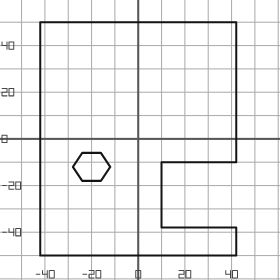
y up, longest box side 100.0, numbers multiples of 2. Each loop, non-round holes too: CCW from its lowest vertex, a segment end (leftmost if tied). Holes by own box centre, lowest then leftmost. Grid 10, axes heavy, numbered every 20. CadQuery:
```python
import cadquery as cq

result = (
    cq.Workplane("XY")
    .moveTo(-42.0, -50.0)
    .lineTo(42.0, -50.0)
    .lineTo(42.0, -38.0)
    .lineTo(10.0, -38.0)
    .lineTo(10.0, -10.0)
    .lineTo(42.0, -10.0)
    .lineTo(42.0, 50.0)
    .lineTo(-42.0, 50.0)
    .close()
    .moveTo(-24.0, -18.0)
    .lineTo(-16.0, -18.0)
    .lineTo(-12.0, -12.0)
    .lineTo(-16.0, -6.0)
    .lineTo(-24.0, -6.0)
    .lineTo(-28.0, -12.0)
    .close()
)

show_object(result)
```